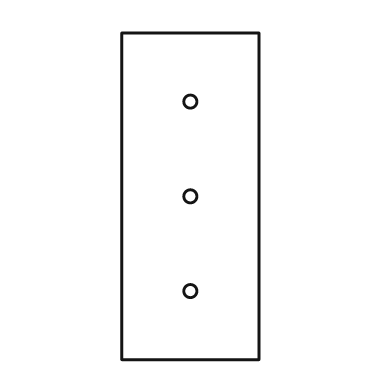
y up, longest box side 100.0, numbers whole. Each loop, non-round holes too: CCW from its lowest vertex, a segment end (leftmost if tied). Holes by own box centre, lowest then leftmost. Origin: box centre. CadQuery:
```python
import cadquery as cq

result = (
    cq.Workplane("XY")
    .moveTo(-21.0, -50.0)
    .lineTo(21.0, -50.0)
    .lineTo(21.0, 50.0)
    .lineTo(-21.0, 50.0)
    .close()
    .moveTo(0.0, -29.0)
    .circle(2.0)
    .moveTo(0.0, 0.0)
    .circle(2.0)
    .moveTo(0.0, 29.0)
    .circle(2.0)
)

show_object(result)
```